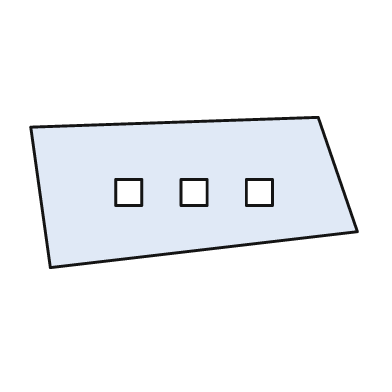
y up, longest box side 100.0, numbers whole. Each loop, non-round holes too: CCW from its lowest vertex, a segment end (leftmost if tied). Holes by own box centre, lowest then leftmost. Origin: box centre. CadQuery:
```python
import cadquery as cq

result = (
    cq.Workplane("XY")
    .moveTo(-44.0, -23.0)
    .lineTo(50.0, -12.0)
    .lineTo(38.0, 23.0)
    .lineTo(-50.0, 20.0)
    .close()
    .moveTo(-24.0, -4.0)
    .lineTo(-16.0, -4.0)
    .lineTo(-16.0, 4.0)
    .lineTo(-24.0, 4.0)
    .close()
    .moveTo(-4.0, -4.0)
    .lineTo(4.0, -4.0)
    .lineTo(4.0, 4.0)
    .lineTo(-4.0, 4.0)
    .close()
    .moveTo(16.0, -4.0)
    .lineTo(24.0, -4.0)
    .lineTo(24.0, 4.0)
    .lineTo(16.0, 4.0)
    .close()
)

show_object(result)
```